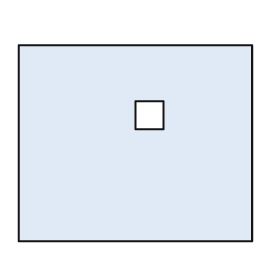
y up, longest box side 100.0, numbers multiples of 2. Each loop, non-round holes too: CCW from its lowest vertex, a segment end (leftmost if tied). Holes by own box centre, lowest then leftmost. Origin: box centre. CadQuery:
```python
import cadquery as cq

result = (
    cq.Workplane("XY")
    .moveTo(-50.0, -42.0)
    .lineTo(50.0, -42.0)
    .lineTo(50.0, 42.0)
    .lineTo(-50.0, 42.0)
    .close()
    .moveTo(0.0, 6.0)
    .lineTo(12.0, 6.0)
    .lineTo(12.0, 18.0)
    .lineTo(0.0, 18.0)
    .close()
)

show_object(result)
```